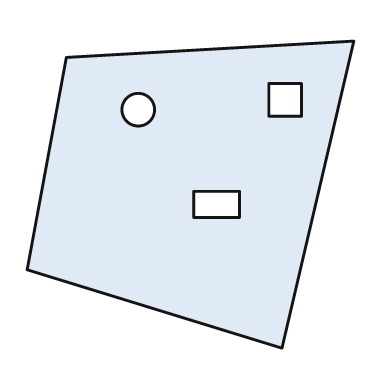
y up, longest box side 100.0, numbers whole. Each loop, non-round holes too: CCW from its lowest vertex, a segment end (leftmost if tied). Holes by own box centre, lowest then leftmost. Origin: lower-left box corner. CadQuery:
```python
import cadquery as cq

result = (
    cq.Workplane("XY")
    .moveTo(78.0, 0.0)
    .lineTo(100.0, 94.0)
    .lineTo(12.0, 89.0)
    .lineTo(0.0, 24.0)
    .close()
    .moveTo(51.0, 40.0)
    .lineTo(65.0, 40.0)
    .lineTo(65.0, 48.0)
    .lineTo(51.0, 48.0)
    .close()
    .moveTo(34.0, 73.0)
    .circle(5.0)
    .moveTo(74.0, 71.0)
    .lineTo(84.0, 71.0)
    .lineTo(84.0, 81.0)
    .lineTo(74.0, 81.0)
    .close()
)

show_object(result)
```